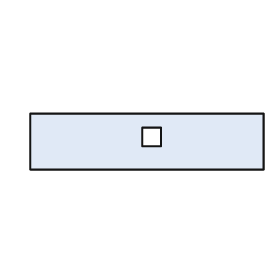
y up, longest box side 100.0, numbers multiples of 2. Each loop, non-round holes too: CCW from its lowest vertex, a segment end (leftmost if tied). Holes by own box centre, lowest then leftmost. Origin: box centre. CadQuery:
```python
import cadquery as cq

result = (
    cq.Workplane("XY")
    .moveTo(-50.0, -12.0)
    .lineTo(50.0, -12.0)
    .lineTo(50.0, 12.0)
    .lineTo(-50.0, 12.0)
    .close()
    .moveTo(-2.0, -2.0)
    .lineTo(6.0, -2.0)
    .lineTo(6.0, 6.0)
    .lineTo(-2.0, 6.0)
    .close()
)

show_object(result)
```